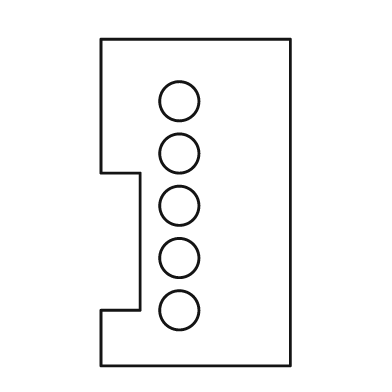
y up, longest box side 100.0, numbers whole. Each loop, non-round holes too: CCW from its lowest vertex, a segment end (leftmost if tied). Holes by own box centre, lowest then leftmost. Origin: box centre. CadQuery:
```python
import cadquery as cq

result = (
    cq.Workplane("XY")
    .moveTo(-29.0, -50.0)
    .lineTo(29.0, -50.0)
    .lineTo(29.0, 50.0)
    .lineTo(-29.0, 50.0)
    .lineTo(-29.0, 9.0)
    .lineTo(-17.0, 9.0)
    .lineTo(-17.0, -33.0)
    .lineTo(-29.0, -33.0)
    .close()
    .moveTo(-5.0, -33.0)
    .circle(6.0)
    .moveTo(-5.0, -17.0)
    .circle(6.0)
    .moveTo(-5.0, -1.0)
    .circle(6.0)
    .moveTo(-5.0, 15.0)
    .circle(6.0)
    .moveTo(-5.0, 31.0)
    .circle(6.0)
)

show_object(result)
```